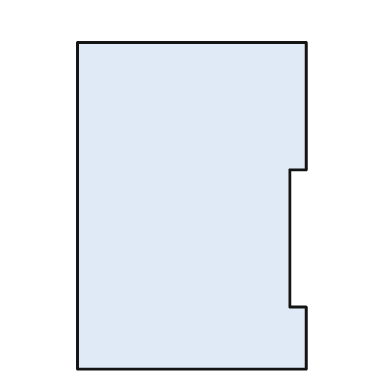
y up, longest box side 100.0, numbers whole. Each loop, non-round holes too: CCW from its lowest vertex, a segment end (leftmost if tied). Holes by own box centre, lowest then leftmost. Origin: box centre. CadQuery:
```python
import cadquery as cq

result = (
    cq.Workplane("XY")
    .moveTo(-35.0, -50.0)
    .lineTo(35.0, -50.0)
    .lineTo(35.0, -31.0)
    .lineTo(30.0, -31.0)
    .lineTo(30.0, 11.0)
    .lineTo(35.0, 11.0)
    .lineTo(35.0, 50.0)
    .lineTo(-35.0, 50.0)
    .close()
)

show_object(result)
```